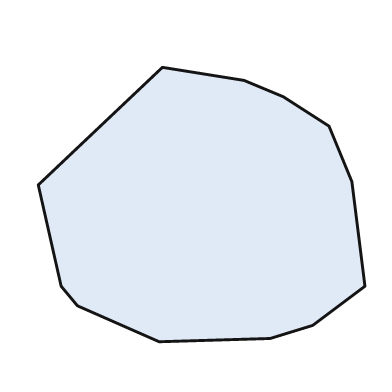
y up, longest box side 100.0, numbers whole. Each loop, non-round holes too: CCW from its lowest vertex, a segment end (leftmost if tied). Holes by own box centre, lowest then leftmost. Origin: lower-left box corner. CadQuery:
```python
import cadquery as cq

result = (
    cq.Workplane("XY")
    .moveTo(37.0, 0.0)
    .lineTo(71.0, 1.0)
    .lineTo(84.0, 5.0)
    .lineTo(100.0, 17.0)
    .lineTo(96.0, 49.0)
    .lineTo(89.0, 66.0)
    .lineTo(75.0, 75.0)
    .lineTo(63.0, 80.0)
    .lineTo(38.0, 84.0)
    .lineTo(0.0, 48.0)
    .lineTo(7.0, 17.0)
    .lineTo(12.0, 11.0)
    .close()
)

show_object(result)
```